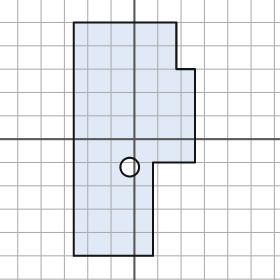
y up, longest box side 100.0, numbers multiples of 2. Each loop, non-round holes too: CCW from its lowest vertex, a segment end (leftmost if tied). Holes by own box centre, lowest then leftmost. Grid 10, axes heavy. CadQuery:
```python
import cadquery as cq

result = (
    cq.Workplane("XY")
    .moveTo(-26.0, -50.0)
    .lineTo(8.0, -50.0)
    .lineTo(8.0, -10.0)
    .lineTo(26.0, -10.0)
    .lineTo(26.0, 30.0)
    .lineTo(18.0, 30.0)
    .lineTo(18.0, 50.0)
    .lineTo(-26.0, 50.0)
    .close()
    .moveTo(-2.0, -12.0)
    .circle(4.0)
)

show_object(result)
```